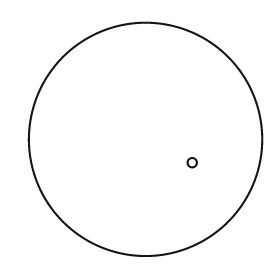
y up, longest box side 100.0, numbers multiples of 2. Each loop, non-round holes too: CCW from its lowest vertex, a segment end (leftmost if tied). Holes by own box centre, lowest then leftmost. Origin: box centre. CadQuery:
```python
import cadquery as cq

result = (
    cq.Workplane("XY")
    .moveTo(0.0, 0.0)
    .circle(50.0)
    .moveTo(20.0, -10.0)
    .circle(2.0)
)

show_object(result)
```